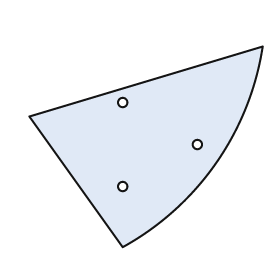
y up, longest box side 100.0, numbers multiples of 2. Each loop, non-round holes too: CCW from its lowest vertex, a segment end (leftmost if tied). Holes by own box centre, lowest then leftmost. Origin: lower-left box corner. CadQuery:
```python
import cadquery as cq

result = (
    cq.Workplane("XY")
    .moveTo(40.0, 0.0)
    .threePointArc((80.0, 36.0), (100.0, 86.0))
    .lineTo(0.0, 56.0)
    .close()
    .moveTo(40.0, 26.0)
    .circle(2.0)
    .moveTo(72.0, 44.0)
    .circle(2.0)
    .moveTo(40.0, 62.0)
    .circle(2.0)
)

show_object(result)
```